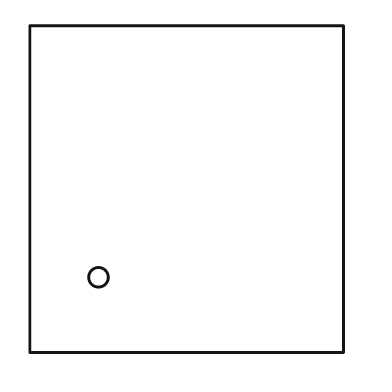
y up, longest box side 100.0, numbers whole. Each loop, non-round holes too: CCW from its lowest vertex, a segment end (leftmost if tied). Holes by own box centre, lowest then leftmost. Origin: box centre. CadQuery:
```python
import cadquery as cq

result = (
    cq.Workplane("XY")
    .moveTo(-48.0, -50.0)
    .lineTo(48.0, -50.0)
    .lineTo(48.0, 50.0)
    .lineTo(-48.0, 50.0)
    .close()
    .moveTo(-27.0, -27.0)
    .circle(3.0)
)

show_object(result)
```